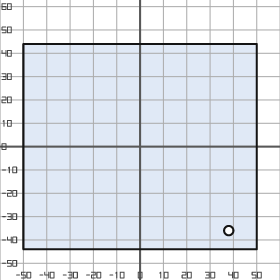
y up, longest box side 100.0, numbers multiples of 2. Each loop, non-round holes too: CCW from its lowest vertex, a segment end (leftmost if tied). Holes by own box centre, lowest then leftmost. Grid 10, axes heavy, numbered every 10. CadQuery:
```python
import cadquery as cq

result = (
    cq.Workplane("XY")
    .moveTo(-50.0, -44.0)
    .lineTo(50.0, -44.0)
    .lineTo(50.0, 44.0)
    .lineTo(-50.0, 44.0)
    .close()
    .moveTo(38.0, -36.0)
    .circle(2.0)
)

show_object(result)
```